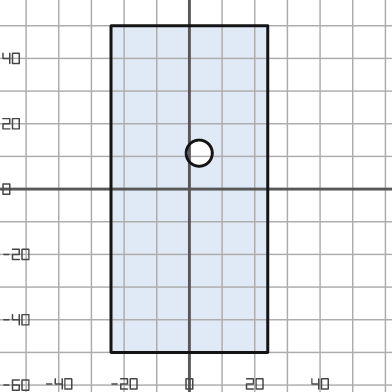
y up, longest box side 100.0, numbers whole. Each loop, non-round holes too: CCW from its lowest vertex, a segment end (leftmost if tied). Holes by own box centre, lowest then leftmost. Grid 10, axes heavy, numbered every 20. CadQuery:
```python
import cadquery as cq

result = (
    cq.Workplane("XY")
    .moveTo(-24.0, -50.0)
    .lineTo(24.0, -50.0)
    .lineTo(24.0, 50.0)
    .lineTo(-24.0, 50.0)
    .close()
    .moveTo(3.0, 11.0)
    .circle(4.0)
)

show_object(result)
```